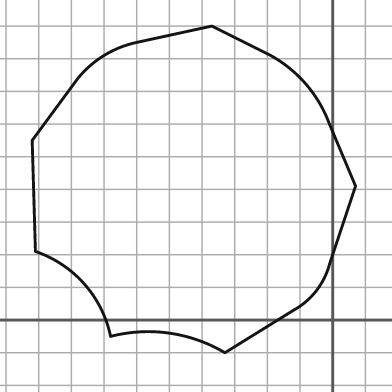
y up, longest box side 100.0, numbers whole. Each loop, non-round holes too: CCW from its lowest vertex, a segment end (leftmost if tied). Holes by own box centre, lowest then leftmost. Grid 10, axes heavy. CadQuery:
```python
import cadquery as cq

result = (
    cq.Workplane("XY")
    .moveTo(-33.0, -10.0)
    .lineTo(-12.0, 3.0)
    .threePointArc((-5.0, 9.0), (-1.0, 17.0))
    .lineTo(7.0, 41.0)
    .lineTo(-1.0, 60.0)
    .threePointArc((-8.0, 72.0), (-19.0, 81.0))
    .lineTo(-37.0, 90.0)
    .lineTo(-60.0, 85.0)
    .threePointArc((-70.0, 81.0), (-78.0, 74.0))
    .lineTo(-92.0, 55.0)
    .lineTo(-91.0, 21.0)
    .threePointArc((-76.0, 11.0), (-68.0, -5.0))
    .threePointArc((-50.0, -4.0), (-33.0, -10.0))
    .close()
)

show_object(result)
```